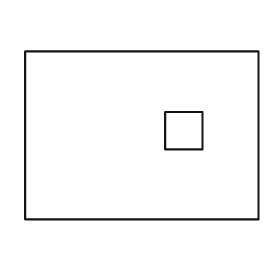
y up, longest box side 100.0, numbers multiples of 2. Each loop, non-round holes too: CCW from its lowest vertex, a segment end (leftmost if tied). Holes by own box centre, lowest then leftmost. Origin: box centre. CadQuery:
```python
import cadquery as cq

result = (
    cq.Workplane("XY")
    .moveTo(-50.0, -36.0)
    .lineTo(50.0, -36.0)
    .lineTo(50.0, 36.0)
    .lineTo(-50.0, 36.0)
    .close()
    .moveTo(10.0, -6.0)
    .lineTo(26.0, -6.0)
    .lineTo(26.0, 10.0)
    .lineTo(10.0, 10.0)
    .close()
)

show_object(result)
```